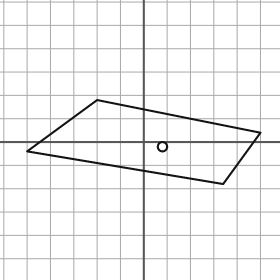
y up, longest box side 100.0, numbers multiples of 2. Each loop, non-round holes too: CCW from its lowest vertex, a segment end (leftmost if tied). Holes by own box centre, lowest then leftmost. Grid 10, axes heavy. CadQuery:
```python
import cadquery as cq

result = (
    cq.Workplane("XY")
    .moveTo(34.0, -18.0)
    .lineTo(50.0, 4.0)
    .lineTo(-20.0, 18.0)
    .lineTo(-50.0, -4.0)
    .close()
    .moveTo(8.0, -2.0)
    .circle(2.0)
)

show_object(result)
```